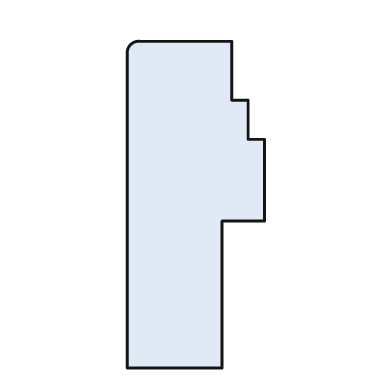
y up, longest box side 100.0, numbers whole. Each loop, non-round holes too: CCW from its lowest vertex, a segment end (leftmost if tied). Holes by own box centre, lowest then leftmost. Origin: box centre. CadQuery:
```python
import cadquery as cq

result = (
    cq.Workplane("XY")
    .moveTo(-21.0, -50.0)
    .lineTo(8.0, -50.0)
    .lineTo(8.0, -5.0)
    .lineTo(21.0, -5.0)
    .lineTo(21.0, 20.0)
    .lineTo(16.0, 20.0)
    .lineTo(16.0, 32.0)
    .lineTo(11.0, 32.0)
    .lineTo(11.0, 50.0)
    .lineTo(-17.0, 50.0)
    .threePointArc((-20.0, 49.0), (-21.0, 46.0))
    .close()
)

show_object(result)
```